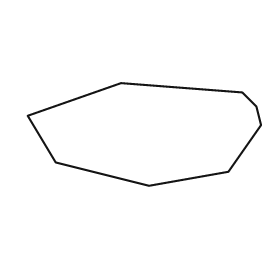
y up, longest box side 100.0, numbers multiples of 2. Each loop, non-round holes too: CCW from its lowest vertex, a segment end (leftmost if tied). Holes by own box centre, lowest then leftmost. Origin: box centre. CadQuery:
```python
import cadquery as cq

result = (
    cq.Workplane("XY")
    .moveTo(2.0, -22.0)
    .lineTo(36.0, -16.0)
    .lineTo(50.0, 4.0)
    .lineTo(48.0, 12.0)
    .lineTo(42.0, 18.0)
    .lineTo(-10.0, 22.0)
    .lineTo(-50.0, 8.0)
    .lineTo(-38.0, -12.0)
    .close()
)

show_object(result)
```